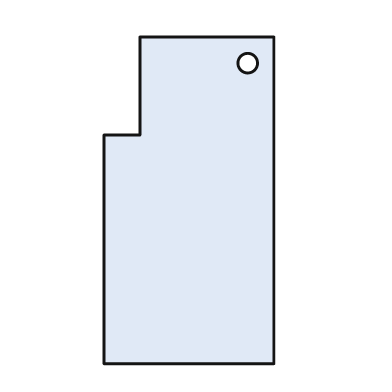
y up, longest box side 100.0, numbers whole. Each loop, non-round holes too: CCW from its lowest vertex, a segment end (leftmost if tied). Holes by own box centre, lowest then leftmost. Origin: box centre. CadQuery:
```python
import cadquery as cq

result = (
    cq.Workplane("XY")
    .moveTo(-26.0, -50.0)
    .lineTo(26.0, -50.0)
    .lineTo(26.0, 50.0)
    .lineTo(-15.0, 50.0)
    .lineTo(-15.0, 20.0)
    .lineTo(-26.0, 20.0)
    .close()
    .moveTo(18.0, 42.0)
    .circle(3.0)
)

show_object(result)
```